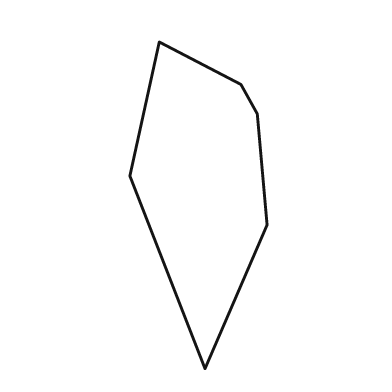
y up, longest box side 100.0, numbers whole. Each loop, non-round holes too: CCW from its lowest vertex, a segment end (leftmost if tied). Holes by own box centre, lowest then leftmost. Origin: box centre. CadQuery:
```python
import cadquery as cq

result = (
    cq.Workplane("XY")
    .moveTo(2.0, -50.0)
    .lineTo(21.0, -6.0)
    .lineTo(18.0, 28.0)
    .lineTo(13.0, 37.0)
    .lineTo(-12.0, 50.0)
    .lineTo(-21.0, 9.0)
    .close()
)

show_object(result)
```